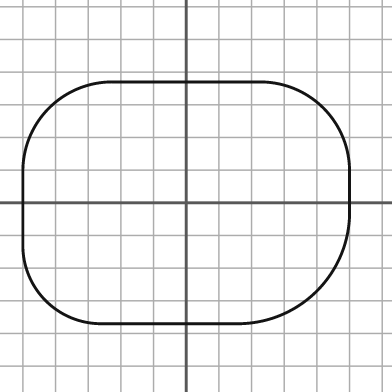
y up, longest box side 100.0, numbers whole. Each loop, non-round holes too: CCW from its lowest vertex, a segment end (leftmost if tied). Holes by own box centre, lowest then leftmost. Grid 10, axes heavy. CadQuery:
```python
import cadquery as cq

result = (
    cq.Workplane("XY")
    .moveTo(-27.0, -37.0)
    .lineTo(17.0, -37.0)
    .threePointArc((40.0, -27.0), (50.0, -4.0))
    .lineTo(50.0, 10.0)
    .threePointArc((42.0, 29.0), (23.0, 37.0))
    .lineTo(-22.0, 37.0)
    .threePointArc((-42.0, 29.0), (-50.0, 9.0))
    .lineTo(-50.0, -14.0)
    .threePointArc((-43.0, -30.0), (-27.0, -37.0))
    .close()
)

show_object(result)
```